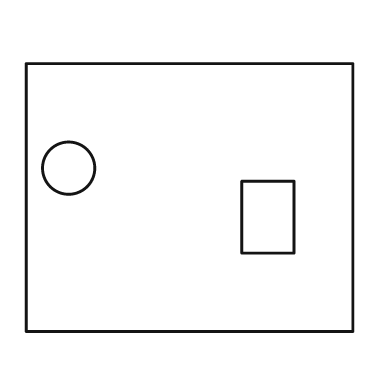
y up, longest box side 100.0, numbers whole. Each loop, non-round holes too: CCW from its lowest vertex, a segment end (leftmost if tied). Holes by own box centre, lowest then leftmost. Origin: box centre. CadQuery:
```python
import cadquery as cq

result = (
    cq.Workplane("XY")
    .moveTo(-50.0, -41.0)
    .lineTo(50.0, -41.0)
    .lineTo(50.0, 41.0)
    .lineTo(-50.0, 41.0)
    .close()
    .moveTo(16.0, -17.0)
    .lineTo(32.0, -17.0)
    .lineTo(32.0, 5.0)
    .lineTo(16.0, 5.0)
    .close()
    .moveTo(-37.0, 9.0)
    .circle(8.0)
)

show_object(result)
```